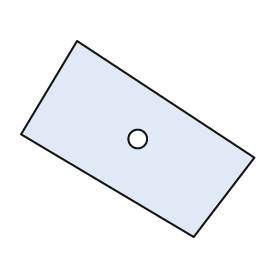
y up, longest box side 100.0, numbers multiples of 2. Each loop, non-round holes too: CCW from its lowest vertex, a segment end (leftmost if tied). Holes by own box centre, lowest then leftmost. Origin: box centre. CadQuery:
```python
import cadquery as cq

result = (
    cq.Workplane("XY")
    .moveTo(24.0, -42.0)
    .lineTo(50.0, -8.0)
    .lineTo(-26.0, 42.0)
    .lineTo(-50.0, 2.0)
    .close()
    .moveTo(0.0, 0.0)
    .circle(4.0)
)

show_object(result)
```